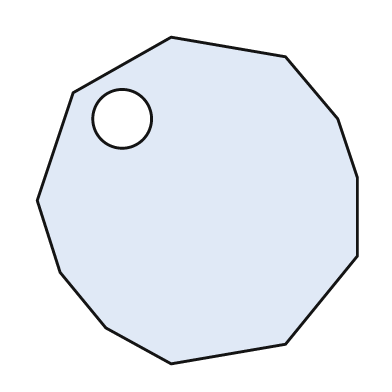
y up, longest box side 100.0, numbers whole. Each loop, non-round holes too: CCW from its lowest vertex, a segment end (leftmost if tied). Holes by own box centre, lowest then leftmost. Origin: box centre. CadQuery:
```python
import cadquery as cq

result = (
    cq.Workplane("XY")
    .moveTo(-8.0, -50.0)
    .lineTo(27.0, -44.0)
    .lineTo(49.0, -17.0)
    .lineTo(49.0, 7.0)
    .lineTo(43.0, 25.0)
    .lineTo(27.0, 44.0)
    .lineTo(-8.0, 50.0)
    .lineTo(-38.0, 33.0)
    .lineTo(-49.0, 0.0)
    .lineTo(-42.0, -22.0)
    .lineTo(-28.0, -39.0)
    .close()
    .moveTo(-23.0, 25.0)
    .circle(9.0)
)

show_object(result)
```